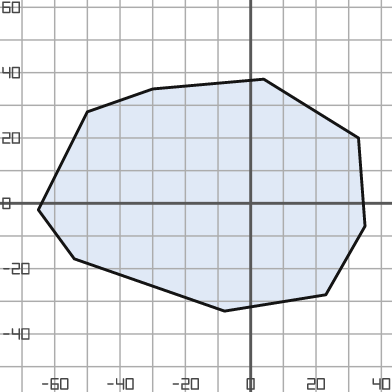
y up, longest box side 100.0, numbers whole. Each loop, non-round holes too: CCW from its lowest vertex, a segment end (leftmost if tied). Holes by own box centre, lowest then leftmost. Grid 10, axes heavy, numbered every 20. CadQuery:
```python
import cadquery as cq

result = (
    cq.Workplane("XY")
    .moveTo(-8.0, -33.0)
    .lineTo(23.0, -28.0)
    .lineTo(35.0, -7.0)
    .lineTo(33.0, 20.0)
    .lineTo(4.0, 38.0)
    .lineTo(-30.0, 35.0)
    .lineTo(-50.0, 28.0)
    .lineTo(-65.0, -2.0)
    .lineTo(-54.0, -17.0)
    .close()
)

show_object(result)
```